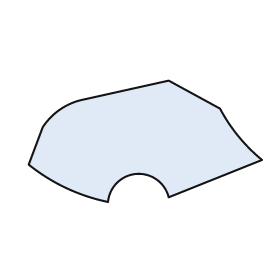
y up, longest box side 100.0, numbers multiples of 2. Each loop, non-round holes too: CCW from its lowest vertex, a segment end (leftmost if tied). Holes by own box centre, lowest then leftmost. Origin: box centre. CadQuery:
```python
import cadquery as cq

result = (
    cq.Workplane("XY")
    .moveTo(-16.0, -26.0)
    .threePointArc((-4.0, -14.0), (10.0, -24.0))
    .lineTo(50.0, -8.0)
    .threePointArc((40.0, 2.0), (32.0, 14.0))
    .lineTo(10.0, 26.0)
    .lineTo(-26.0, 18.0)
    .threePointArc((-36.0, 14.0), (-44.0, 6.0))
    .lineTo(-50.0, -10.0)
    .threePointArc((-34.0, -20.0), (-16.0, -26.0))
    .close()
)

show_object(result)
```